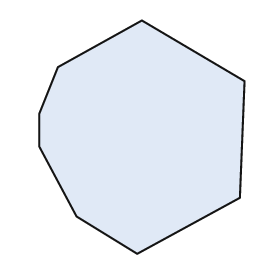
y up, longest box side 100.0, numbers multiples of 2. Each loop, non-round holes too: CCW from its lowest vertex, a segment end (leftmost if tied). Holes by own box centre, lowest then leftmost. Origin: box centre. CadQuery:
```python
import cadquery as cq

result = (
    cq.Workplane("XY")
    .moveTo(-2.0, -50.0)
    .lineTo(42.0, -26.0)
    .lineTo(44.0, 24.0)
    .lineTo(0.0, 50.0)
    .lineTo(-36.0, 30.0)
    .lineTo(-44.0, 10.0)
    .lineTo(-44.0, -4.0)
    .lineTo(-28.0, -34.0)
    .close()
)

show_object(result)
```